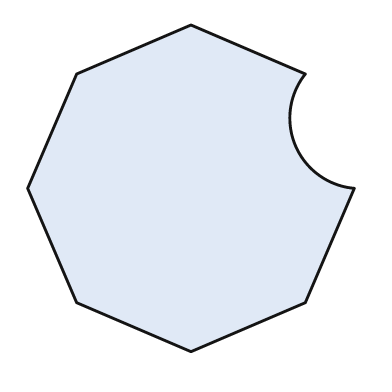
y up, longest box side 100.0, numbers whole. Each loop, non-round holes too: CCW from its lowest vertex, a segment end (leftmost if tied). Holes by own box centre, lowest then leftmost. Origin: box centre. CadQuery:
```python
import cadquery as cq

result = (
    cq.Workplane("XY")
    .moveTo(0.0, -50.0)
    .lineTo(35.0, -35.0)
    .lineTo(50.0, 0.0)
    .threePointArc((32.0, 13.0), (35.0, 35.0))
    .lineTo(0.0, 50.0)
    .lineTo(-35.0, 35.0)
    .lineTo(-50.0, 0.0)
    .lineTo(-35.0, -35.0)
    .close()
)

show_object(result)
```